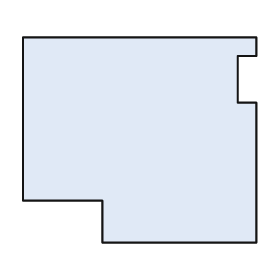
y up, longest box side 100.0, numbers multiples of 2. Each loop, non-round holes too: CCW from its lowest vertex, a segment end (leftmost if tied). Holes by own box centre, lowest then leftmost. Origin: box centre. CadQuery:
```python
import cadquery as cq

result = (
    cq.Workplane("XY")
    .moveTo(-16.0, -44.0)
    .lineTo(50.0, -44.0)
    .lineTo(50.0, 16.0)
    .lineTo(42.0, 16.0)
    .lineTo(42.0, 36.0)
    .lineTo(50.0, 36.0)
    .lineTo(50.0, 44.0)
    .lineTo(-50.0, 44.0)
    .lineTo(-50.0, -26.0)
    .lineTo(-16.0, -26.0)
    .close()
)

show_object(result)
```